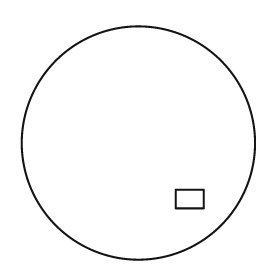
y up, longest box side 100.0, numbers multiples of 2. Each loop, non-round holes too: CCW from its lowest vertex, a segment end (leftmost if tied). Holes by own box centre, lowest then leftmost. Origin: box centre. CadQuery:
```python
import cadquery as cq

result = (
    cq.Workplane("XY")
    .moveTo(0.0, 0.0)
    .circle(50.0)
    .moveTo(16.0, -28.0)
    .lineTo(28.0, -28.0)
    .lineTo(28.0, -20.0)
    .lineTo(16.0, -20.0)
    .close()
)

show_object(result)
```